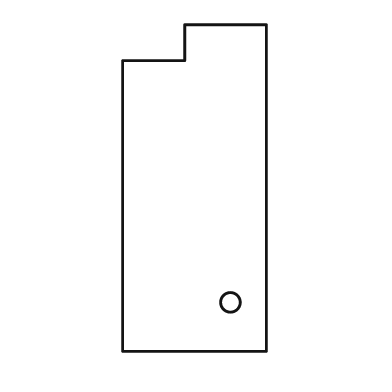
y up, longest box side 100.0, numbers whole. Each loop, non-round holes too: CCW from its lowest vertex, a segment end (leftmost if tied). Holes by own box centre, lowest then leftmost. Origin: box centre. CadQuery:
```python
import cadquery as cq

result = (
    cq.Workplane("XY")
    .moveTo(-22.0, -50.0)
    .lineTo(22.0, -50.0)
    .lineTo(22.0, 50.0)
    .lineTo(-3.0, 50.0)
    .lineTo(-3.0, 39.0)
    .lineTo(-22.0, 39.0)
    .close()
    .moveTo(11.0, -35.0)
    .circle(3.0)
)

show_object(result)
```